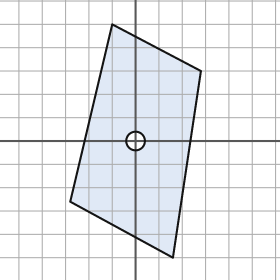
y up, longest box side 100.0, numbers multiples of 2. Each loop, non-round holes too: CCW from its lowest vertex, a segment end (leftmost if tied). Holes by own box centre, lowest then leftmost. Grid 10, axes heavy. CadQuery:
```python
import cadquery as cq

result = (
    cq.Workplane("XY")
    .moveTo(16.0, -50.0)
    .lineTo(28.0, 30.0)
    .lineTo(-10.0, 50.0)
    .lineTo(-28.0, -26.0)
    .close()
    .moveTo(0.0, 0.0)
    .circle(4.0)
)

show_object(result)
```